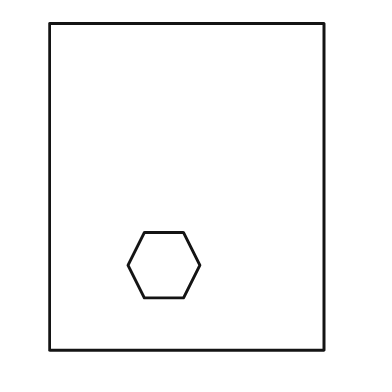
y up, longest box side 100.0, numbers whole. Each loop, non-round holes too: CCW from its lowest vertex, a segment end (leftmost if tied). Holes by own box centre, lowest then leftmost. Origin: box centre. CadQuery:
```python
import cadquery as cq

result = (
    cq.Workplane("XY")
    .moveTo(-42.0, -50.0)
    .lineTo(42.0, -50.0)
    .lineTo(42.0, 50.0)
    .lineTo(-42.0, 50.0)
    .close()
    .moveTo(-13.0, -34.0)
    .lineTo(-1.0, -34.0)
    .lineTo(4.0, -24.0)
    .lineTo(-1.0, -14.0)
    .lineTo(-13.0, -14.0)
    .lineTo(-18.0, -24.0)
    .close()
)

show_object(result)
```